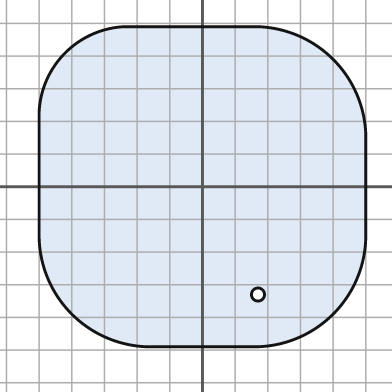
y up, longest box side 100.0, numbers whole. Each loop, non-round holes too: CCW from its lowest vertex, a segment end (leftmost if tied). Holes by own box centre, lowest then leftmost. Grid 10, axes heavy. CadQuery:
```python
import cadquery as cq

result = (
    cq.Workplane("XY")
    .moveTo(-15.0, -49.0)
    .lineTo(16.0, -49.0)
    .threePointArc((40.0, -39.0), (50.0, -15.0))
    .lineTo(50.0, 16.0)
    .threePointArc((40.0, 39.0), (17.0, 49.0))
    .lineTo(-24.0, 49.0)
    .threePointArc((-42.0, 41.0), (-50.0, 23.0))
    .lineTo(-50.0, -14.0)
    .threePointArc((-40.0, -39.0), (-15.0, -49.0))
    .close()
    .moveTo(17.0, -33.0)
    .circle(2.0)
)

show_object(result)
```